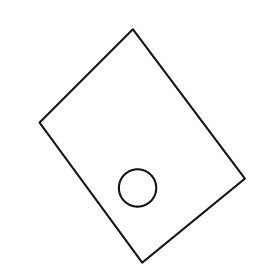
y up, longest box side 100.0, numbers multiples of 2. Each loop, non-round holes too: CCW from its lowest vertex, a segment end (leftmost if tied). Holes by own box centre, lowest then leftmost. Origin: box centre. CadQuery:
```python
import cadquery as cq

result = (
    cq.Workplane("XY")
    .moveTo(0.0, -50.0)
    .lineTo(44.0, -14.0)
    .lineTo(-4.0, 50.0)
    .lineTo(-44.0, 10.0)
    .close()
    .moveTo(-2.0, -18.0)
    .circle(8.0)
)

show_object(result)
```